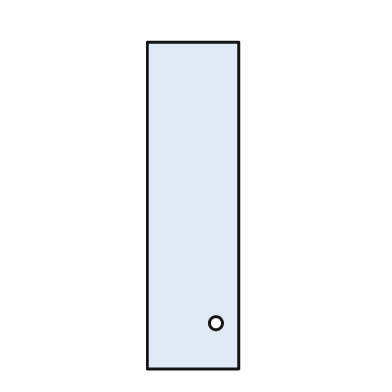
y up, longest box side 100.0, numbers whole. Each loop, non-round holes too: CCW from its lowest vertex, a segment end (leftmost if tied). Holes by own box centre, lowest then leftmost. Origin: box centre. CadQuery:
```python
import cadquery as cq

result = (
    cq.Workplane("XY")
    .moveTo(-14.0, -50.0)
    .lineTo(14.0, -50.0)
    .lineTo(14.0, 50.0)
    .lineTo(-14.0, 50.0)
    .close()
    .moveTo(7.0, -36.0)
    .circle(2.0)
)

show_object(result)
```